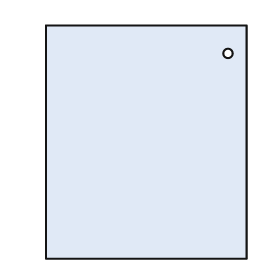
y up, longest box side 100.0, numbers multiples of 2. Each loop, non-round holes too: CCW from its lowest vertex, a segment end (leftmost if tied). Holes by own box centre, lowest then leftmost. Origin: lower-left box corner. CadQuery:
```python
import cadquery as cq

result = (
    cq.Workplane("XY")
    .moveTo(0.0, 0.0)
    .lineTo(86.0, 0.0)
    .lineTo(86.0, 100.0)
    .lineTo(0.0, 100.0)
    .close()
    .moveTo(78.0, 88.0)
    .circle(2.0)
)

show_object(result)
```